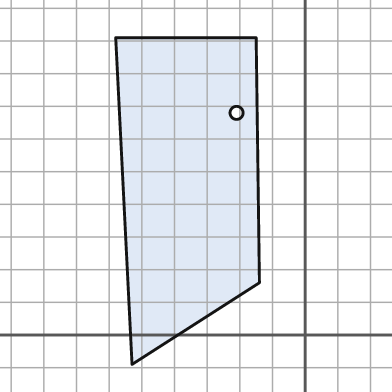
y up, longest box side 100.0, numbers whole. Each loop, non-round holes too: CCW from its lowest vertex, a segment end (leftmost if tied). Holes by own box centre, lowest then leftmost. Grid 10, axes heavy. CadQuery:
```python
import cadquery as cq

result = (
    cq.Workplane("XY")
    .moveTo(-53.0, -9.0)
    .lineTo(-14.0, 16.0)
    .lineTo(-15.0, 91.0)
    .lineTo(-58.0, 91.0)
    .close()
    .moveTo(-21.0, 68.0)
    .circle(2.0)
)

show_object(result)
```